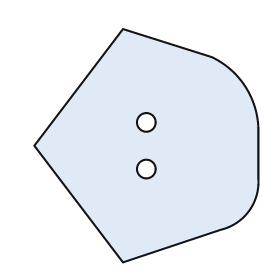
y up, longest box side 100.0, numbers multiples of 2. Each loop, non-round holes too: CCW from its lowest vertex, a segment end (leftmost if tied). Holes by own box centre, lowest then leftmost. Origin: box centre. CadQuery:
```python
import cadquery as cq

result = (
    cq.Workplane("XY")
    .moveTo(-10.0, -50.0)
    .lineTo(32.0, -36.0)
    .threePointArc((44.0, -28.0), (48.0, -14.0))
    .lineTo(48.0, 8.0)
    .threePointArc((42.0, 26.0), (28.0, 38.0))
    .lineTo(-10.0, 50.0)
    .lineTo(-48.0, 0.0)
    .close()
    .moveTo(0.0, -10.0)
    .circle(4.0)
    .moveTo(0.0, 10.0)
    .circle(4.0)
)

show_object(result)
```